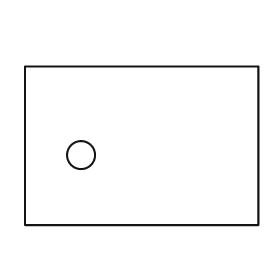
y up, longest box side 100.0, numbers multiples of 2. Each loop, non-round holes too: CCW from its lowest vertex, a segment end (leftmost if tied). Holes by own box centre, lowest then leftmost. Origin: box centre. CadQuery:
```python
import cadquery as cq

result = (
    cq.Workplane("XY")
    .moveTo(-50.0, -34.0)
    .lineTo(50.0, -34.0)
    .lineTo(50.0, 34.0)
    .lineTo(-50.0, 34.0)
    .close()
    .moveTo(-26.0, -4.0)
    .circle(6.0)
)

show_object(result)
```